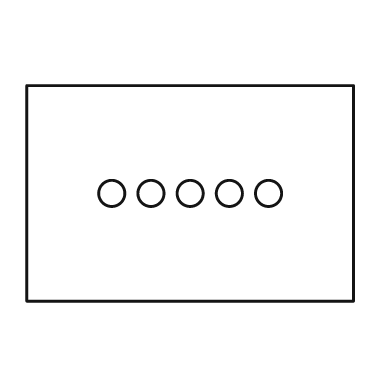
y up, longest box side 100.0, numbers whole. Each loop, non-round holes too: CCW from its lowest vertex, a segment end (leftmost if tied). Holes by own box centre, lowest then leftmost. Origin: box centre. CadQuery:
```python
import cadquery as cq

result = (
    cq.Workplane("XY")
    .moveTo(-50.0, -33.0)
    .lineTo(50.0, -33.0)
    .lineTo(50.0, 33.0)
    .lineTo(-50.0, 33.0)
    .close()
    .moveTo(-24.0, 0.0)
    .circle(4.0)
    .moveTo(-12.0, 0.0)
    .circle(4.0)
    .moveTo(0.0, 0.0)
    .circle(4.0)
    .moveTo(12.0, 0.0)
    .circle(4.0)
    .moveTo(24.0, 0.0)
    .circle(4.0)
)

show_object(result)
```